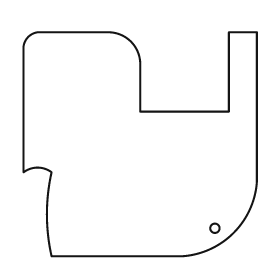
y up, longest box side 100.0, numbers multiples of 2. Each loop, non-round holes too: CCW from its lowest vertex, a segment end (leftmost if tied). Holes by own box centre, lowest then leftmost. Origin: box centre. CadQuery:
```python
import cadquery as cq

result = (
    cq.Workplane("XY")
    .moveTo(-38.0, -48.0)
    .lineTo(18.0, -48.0)
    .threePointArc((40.0, -38.0), (50.0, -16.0))
    .lineTo(50.0, 48.0)
    .lineTo(38.0, 48.0)
    .lineTo(38.0, 14.0)
    .lineTo(0.0, 14.0)
    .lineTo(0.0, 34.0)
    .threePointArc((-4.0, 44.0), (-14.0, 48.0))
    .lineTo(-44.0, 48.0)
    .threePointArc((-48.0, 46.0), (-50.0, 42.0))
    .lineTo(-50.0, -12.0)
    .threePointArc((-44.0, -10.0), (-38.0, -12.0))
    .threePointArc((-40.0, -30.0), (-38.0, -48.0))
    .close()
    .moveTo(32.0, -36.0)
    .circle(2.0)
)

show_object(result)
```